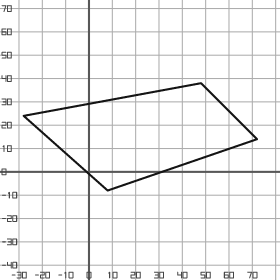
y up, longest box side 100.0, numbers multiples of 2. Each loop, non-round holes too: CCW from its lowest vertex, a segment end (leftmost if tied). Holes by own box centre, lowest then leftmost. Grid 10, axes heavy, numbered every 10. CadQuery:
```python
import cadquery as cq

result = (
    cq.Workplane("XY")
    .moveTo(8.0, -8.0)
    .lineTo(72.0, 14.0)
    .lineTo(48.0, 38.0)
    .lineTo(-28.0, 24.0)
    .close()
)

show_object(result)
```